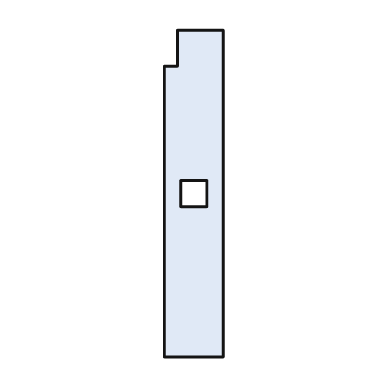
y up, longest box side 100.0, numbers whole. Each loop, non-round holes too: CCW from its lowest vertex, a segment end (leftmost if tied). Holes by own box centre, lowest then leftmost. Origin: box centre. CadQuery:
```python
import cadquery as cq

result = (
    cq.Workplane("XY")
    .moveTo(-9.0, -50.0)
    .lineTo(9.0, -50.0)
    .lineTo(9.0, 50.0)
    .lineTo(-5.0, 50.0)
    .lineTo(-5.0, 39.0)
    .lineTo(-9.0, 39.0)
    .close()
    .moveTo(-4.0, -4.0)
    .lineTo(4.0, -4.0)
    .lineTo(4.0, 4.0)
    .lineTo(-4.0, 4.0)
    .close()
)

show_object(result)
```